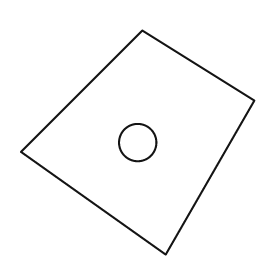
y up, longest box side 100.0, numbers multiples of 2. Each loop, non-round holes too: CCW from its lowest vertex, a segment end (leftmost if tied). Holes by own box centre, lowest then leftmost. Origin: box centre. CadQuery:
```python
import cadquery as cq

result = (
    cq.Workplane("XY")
    .moveTo(12.0, -48.0)
    .lineTo(50.0, 18.0)
    .lineTo(2.0, 48.0)
    .lineTo(-50.0, -4.0)
    .close()
    .moveTo(0.0, 0.0)
    .circle(8.0)
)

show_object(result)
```